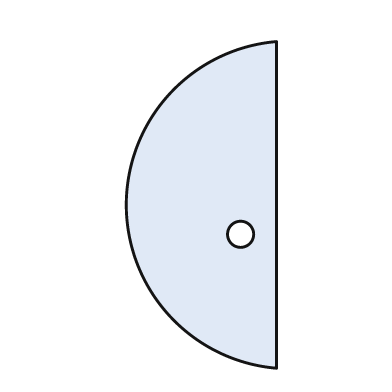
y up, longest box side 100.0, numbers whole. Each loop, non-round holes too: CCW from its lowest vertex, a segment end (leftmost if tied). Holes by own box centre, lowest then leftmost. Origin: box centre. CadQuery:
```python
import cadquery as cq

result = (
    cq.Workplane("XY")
    .moveTo(23.0, -50.0)
    .lineTo(23.0, 50.0)
    .threePointArc((-23.0, 0.0), (23.0, -50.0))
    .close()
    .moveTo(12.0, -9.0)
    .circle(4.0)
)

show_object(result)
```